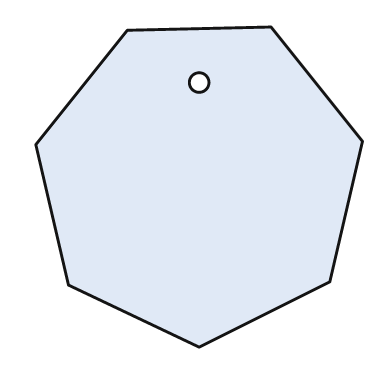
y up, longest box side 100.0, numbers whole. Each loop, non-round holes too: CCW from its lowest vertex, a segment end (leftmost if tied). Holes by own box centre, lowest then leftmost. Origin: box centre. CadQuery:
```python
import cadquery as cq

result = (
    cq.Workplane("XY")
    .moveTo(0.0, -49.0)
    .lineTo(40.0, -29.0)
    .lineTo(50.0, 14.0)
    .lineTo(22.0, 49.0)
    .lineTo(-22.0, 48.0)
    .lineTo(-50.0, 13.0)
    .lineTo(-40.0, -30.0)
    .close()
    .moveTo(0.0, 32.0)
    .circle(3.0)
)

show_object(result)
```